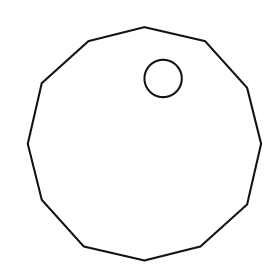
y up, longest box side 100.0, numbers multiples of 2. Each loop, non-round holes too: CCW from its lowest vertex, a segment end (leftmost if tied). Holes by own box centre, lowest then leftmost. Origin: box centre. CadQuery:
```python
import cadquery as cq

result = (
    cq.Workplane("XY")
    .moveTo(0.0, -50.0)
    .lineTo(24.0, -44.0)
    .lineTo(44.0, -26.0)
    .lineTo(50.0, 0.0)
    .lineTo(44.0, 24.0)
    .lineTo(26.0, 44.0)
    .lineTo(0.0, 50.0)
    .lineTo(-24.0, 44.0)
    .lineTo(-44.0, 26.0)
    .lineTo(-50.0, 0.0)
    .lineTo(-44.0, -24.0)
    .lineTo(-26.0, -44.0)
    .close()
    .moveTo(8.0, 28.0)
    .circle(8.0)
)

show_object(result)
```